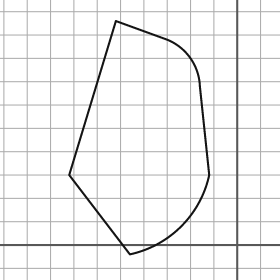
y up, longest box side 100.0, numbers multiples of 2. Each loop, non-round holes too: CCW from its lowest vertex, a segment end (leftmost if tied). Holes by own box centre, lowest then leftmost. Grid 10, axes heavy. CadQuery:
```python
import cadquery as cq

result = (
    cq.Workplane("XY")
    .moveTo(-46.0, -4.0)
    .threePointArc((-24.0, 8.0), (-12.0, 30.0))
    .lineTo(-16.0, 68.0)
    .threePointArc((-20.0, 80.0), (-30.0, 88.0))
    .lineTo(-52.0, 96.0)
    .lineTo(-72.0, 30.0)
    .close()
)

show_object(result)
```